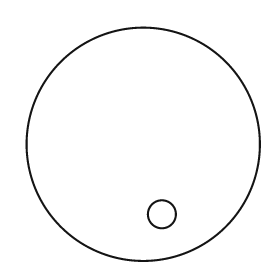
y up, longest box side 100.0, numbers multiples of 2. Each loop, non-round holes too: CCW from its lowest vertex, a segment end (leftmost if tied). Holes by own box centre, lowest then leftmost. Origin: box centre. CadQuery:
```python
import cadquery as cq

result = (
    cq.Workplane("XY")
    .moveTo(0.0, 0.0)
    .circle(50.0)
    .moveTo(8.0, -30.0)
    .circle(6.0)
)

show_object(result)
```